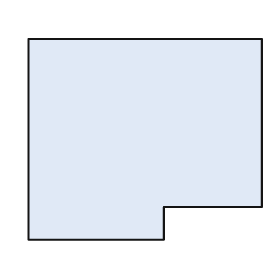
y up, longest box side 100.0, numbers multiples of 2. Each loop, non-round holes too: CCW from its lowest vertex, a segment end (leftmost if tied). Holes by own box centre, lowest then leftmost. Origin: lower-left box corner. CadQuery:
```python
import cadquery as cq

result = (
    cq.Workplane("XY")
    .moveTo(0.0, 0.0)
    .lineTo(58.0, 0.0)
    .lineTo(58.0, 14.0)
    .lineTo(100.0, 14.0)
    .lineTo(100.0, 86.0)
    .lineTo(0.0, 86.0)
    .close()
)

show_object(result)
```